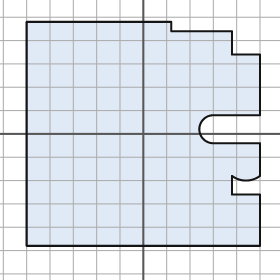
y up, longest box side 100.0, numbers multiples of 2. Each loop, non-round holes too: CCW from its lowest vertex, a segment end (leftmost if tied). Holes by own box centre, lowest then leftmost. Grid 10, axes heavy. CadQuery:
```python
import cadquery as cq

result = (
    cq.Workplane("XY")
    .moveTo(-50.0, -48.0)
    .lineTo(50.0, -48.0)
    .lineTo(50.0, -26.0)
    .lineTo(38.0, -26.0)
    .lineTo(38.0, -18.0)
    .threePointArc((44.0, -20.0), (50.0, -18.0))
    .lineTo(50.0, -4.0)
    .lineTo(30.0, -4.0)
    .threePointArc((24.0, 2.0), (30.0, 8.0))
    .lineTo(50.0, 8.0)
    .lineTo(50.0, 34.0)
    .lineTo(38.0, 34.0)
    .lineTo(38.0, 44.0)
    .lineTo(12.0, 44.0)
    .lineTo(12.0, 48.0)
    .lineTo(-50.0, 48.0)
    .close()
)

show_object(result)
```